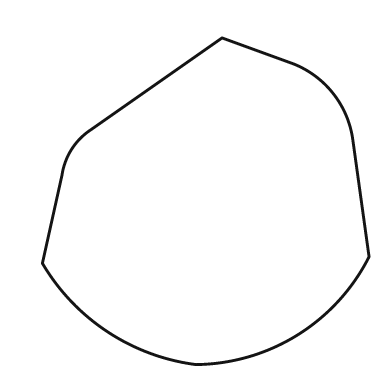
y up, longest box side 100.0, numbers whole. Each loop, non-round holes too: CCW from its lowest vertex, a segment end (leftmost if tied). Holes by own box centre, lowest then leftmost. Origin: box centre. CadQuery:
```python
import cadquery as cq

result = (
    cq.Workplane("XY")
    .moveTo(-3.0, -50.0)
    .threePointArc((28.0, -41.0), (50.0, -17.0))
    .lineTo(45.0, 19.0)
    .threePointArc((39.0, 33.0), (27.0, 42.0))
    .lineTo(5.0, 50.0)
    .lineTo(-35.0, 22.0)
    .threePointArc((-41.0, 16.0), (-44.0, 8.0))
    .lineTo(-50.0, -19.0)
    .threePointArc((-30.0, -40.0), (-3.0, -50.0))
    .close()
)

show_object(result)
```